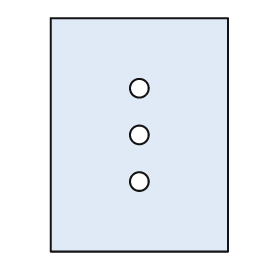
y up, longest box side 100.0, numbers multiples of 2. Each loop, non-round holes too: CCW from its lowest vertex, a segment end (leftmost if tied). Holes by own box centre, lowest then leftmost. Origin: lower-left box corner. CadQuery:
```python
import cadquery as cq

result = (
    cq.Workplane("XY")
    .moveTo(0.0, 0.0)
    .lineTo(76.0, 0.0)
    .lineTo(76.0, 100.0)
    .lineTo(0.0, 100.0)
    .close()
    .moveTo(38.0, 30.0)
    .circle(4.0)
    .moveTo(38.0, 50.0)
    .circle(4.0)
    .moveTo(38.0, 70.0)
    .circle(4.0)
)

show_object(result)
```